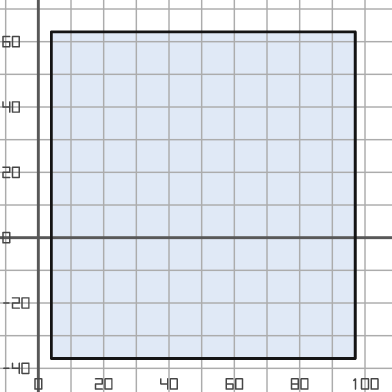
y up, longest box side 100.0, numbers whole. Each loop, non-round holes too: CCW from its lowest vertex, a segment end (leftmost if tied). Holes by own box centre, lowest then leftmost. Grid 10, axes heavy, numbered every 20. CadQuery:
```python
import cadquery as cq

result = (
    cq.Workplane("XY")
    .moveTo(4.0, -37.0)
    .lineTo(97.0, -37.0)
    .lineTo(97.0, 63.0)
    .lineTo(4.0, 63.0)
    .close()
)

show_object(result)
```